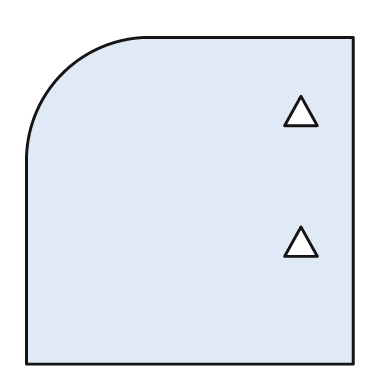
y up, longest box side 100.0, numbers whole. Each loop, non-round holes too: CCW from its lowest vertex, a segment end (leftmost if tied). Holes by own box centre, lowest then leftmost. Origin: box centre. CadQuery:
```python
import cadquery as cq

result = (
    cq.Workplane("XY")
    .moveTo(-50.0, -50.0)
    .lineTo(50.0, -50.0)
    .lineTo(50.0, 50.0)
    .lineTo(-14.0, 50.0)
    .threePointArc((-39.0, 39.0), (-50.0, 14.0))
    .close()
    .moveTo(29.0, -17.0)
    .lineTo(39.0, -17.0)
    .lineTo(34.0, -8.0)
    .close()
    .moveTo(29.0, 23.0)
    .lineTo(39.0, 23.0)
    .lineTo(34.0, 32.0)
    .close()
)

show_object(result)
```